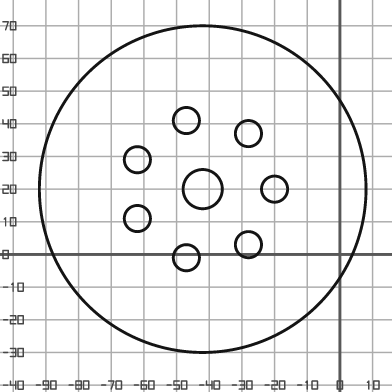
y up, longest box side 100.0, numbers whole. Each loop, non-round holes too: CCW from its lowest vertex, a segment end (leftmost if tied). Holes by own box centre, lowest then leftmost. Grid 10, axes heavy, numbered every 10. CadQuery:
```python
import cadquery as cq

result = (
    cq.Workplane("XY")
    .moveTo(-42.0, 20.0)
    .circle(50.0)
    .moveTo(-47.0, -1.0)
    .circle(4.0)
    .moveTo(-28.0, 3.0)
    .circle(4.0)
    .moveTo(-62.0, 11.0)
    .circle(4.0)
    .moveTo(-42.0, 20.0)
    .circle(6.0)
    .moveTo(-20.0, 20.0)
    .circle(4.0)
    .moveTo(-62.0, 29.0)
    .circle(4.0)
    .moveTo(-28.0, 37.0)
    .circle(4.0)
    .moveTo(-47.0, 41.0)
    .circle(4.0)
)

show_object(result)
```